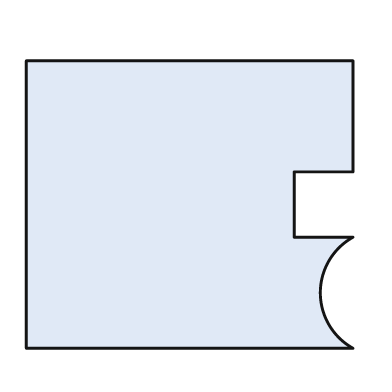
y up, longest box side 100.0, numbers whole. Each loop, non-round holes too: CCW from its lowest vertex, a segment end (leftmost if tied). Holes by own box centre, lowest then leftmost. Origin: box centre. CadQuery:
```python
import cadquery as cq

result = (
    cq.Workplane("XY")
    .moveTo(-50.0, -44.0)
    .lineTo(50.0, -44.0)
    .threePointArc((40.0, -27.0), (50.0, -10.0))
    .lineTo(32.0, -10.0)
    .lineTo(32.0, 10.0)
    .lineTo(50.0, 10.0)
    .lineTo(50.0, 44.0)
    .lineTo(-50.0, 44.0)
    .close()
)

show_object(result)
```